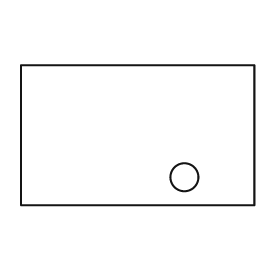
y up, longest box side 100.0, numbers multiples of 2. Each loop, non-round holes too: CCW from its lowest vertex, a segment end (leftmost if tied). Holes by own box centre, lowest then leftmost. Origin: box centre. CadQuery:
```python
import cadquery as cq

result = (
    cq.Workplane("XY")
    .moveTo(-50.0, -30.0)
    .lineTo(50.0, -30.0)
    .lineTo(50.0, 30.0)
    .lineTo(-50.0, 30.0)
    .close()
    .moveTo(20.0, -18.0)
    .circle(6.0)
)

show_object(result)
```